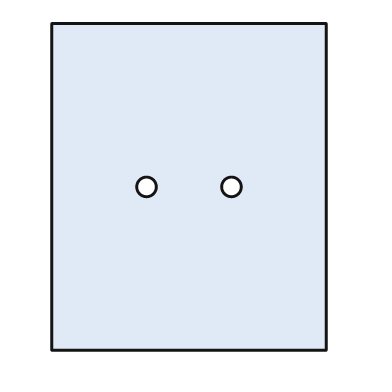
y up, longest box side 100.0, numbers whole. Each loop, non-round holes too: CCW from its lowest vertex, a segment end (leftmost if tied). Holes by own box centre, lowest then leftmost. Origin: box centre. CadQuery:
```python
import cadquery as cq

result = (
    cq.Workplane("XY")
    .moveTo(-42.0, -50.0)
    .lineTo(42.0, -50.0)
    .lineTo(42.0, 50.0)
    .lineTo(-42.0, 50.0)
    .close()
    .moveTo(-13.0, 0.0)
    .circle(3.0)
    .moveTo(13.0, 0.0)
    .circle(3.0)
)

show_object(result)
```